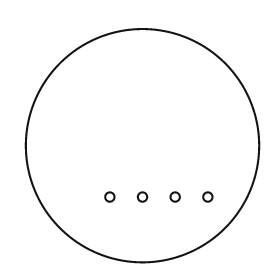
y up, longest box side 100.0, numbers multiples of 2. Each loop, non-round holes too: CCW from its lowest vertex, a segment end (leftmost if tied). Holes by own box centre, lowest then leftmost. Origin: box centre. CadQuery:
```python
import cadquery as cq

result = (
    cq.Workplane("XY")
    .moveTo(0.0, 0.0)
    .circle(50.0)
    .moveTo(-14.0, -22.0)
    .circle(2.0)
    .moveTo(0.0, -22.0)
    .circle(2.0)
    .moveTo(14.0, -22.0)
    .circle(2.0)
    .moveTo(28.0, -22.0)
    .circle(2.0)
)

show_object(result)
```